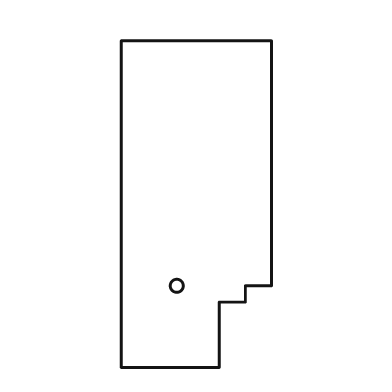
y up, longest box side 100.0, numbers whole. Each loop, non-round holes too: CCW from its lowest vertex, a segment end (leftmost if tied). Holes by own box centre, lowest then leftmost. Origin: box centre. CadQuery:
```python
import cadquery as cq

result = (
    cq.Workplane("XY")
    .moveTo(-23.0, -50.0)
    .lineTo(7.0, -50.0)
    .lineTo(7.0, -30.0)
    .lineTo(15.0, -30.0)
    .lineTo(15.0, -25.0)
    .lineTo(23.0, -25.0)
    .lineTo(23.0, 50.0)
    .lineTo(-23.0, 50.0)
    .close()
    .moveTo(-6.0, -25.0)
    .circle(2.0)
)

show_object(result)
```